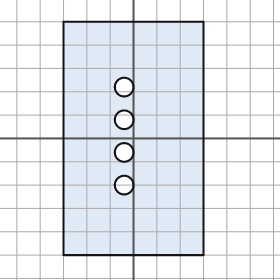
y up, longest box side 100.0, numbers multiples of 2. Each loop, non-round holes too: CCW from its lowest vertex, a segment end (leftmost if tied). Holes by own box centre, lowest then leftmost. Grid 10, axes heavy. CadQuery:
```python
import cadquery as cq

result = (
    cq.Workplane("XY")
    .moveTo(-30.0, -50.0)
    .lineTo(30.0, -50.0)
    .lineTo(30.0, 50.0)
    .lineTo(-30.0, 50.0)
    .close()
    .moveTo(-4.0, -20.0)
    .circle(4.0)
    .moveTo(-4.0, -6.0)
    .circle(4.0)
    .moveTo(-4.0, 8.0)
    .circle(4.0)
    .moveTo(-4.0, 22.0)
    .circle(4.0)
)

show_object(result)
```